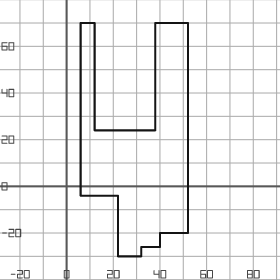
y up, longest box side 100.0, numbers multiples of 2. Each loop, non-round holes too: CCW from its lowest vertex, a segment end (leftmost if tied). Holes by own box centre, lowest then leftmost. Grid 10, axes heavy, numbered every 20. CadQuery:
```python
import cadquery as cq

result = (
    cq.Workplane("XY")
    .moveTo(22.0, -30.0)
    .lineTo(32.0, -30.0)
    .lineTo(32.0, -26.0)
    .lineTo(40.0, -26.0)
    .lineTo(40.0, -20.0)
    .lineTo(52.0, -20.0)
    .lineTo(52.0, 70.0)
    .lineTo(38.0, 70.0)
    .lineTo(38.0, 24.0)
    .lineTo(12.0, 24.0)
    .lineTo(12.0, 70.0)
    .lineTo(6.0, 70.0)
    .lineTo(6.0, -4.0)
    .lineTo(22.0, -4.0)
    .close()
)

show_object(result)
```